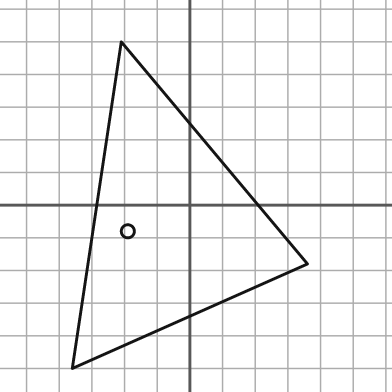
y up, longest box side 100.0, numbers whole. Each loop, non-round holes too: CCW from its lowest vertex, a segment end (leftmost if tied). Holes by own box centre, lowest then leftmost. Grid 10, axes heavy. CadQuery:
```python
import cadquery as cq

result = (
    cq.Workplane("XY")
    .moveTo(-36.0, -50.0)
    .lineTo(36.0, -18.0)
    .lineTo(-21.0, 50.0)
    .close()
    .moveTo(-19.0, -8.0)
    .circle(2.0)
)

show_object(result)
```